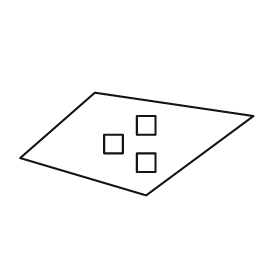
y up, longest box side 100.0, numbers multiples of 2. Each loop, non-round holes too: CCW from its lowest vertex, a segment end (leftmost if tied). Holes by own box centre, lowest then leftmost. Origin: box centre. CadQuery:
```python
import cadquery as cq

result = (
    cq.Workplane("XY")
    .moveTo(4.0, -22.0)
    .lineTo(50.0, 12.0)
    .lineTo(-18.0, 22.0)
    .lineTo(-50.0, -6.0)
    .close()
    .moveTo(0.0, -12.0)
    .lineTo(8.0, -12.0)
    .lineTo(8.0, -4.0)
    .lineTo(0.0, -4.0)
    .close()
    .moveTo(-14.0, -4.0)
    .lineTo(-6.0, -4.0)
    .lineTo(-6.0, 4.0)
    .lineTo(-14.0, 4.0)
    .close()
    .moveTo(0.0, 4.0)
    .lineTo(8.0, 4.0)
    .lineTo(8.0, 12.0)
    .lineTo(0.0, 12.0)
    .close()
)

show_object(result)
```